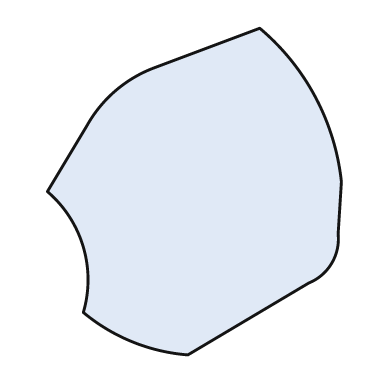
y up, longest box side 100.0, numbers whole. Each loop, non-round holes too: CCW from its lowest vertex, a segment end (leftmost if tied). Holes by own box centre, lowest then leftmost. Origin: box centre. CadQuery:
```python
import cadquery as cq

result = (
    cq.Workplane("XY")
    .moveTo(-2.0, -50.0)
    .lineTo(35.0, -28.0)
    .threePointArc((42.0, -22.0), (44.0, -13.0))
    .lineTo(45.0, 3.0)
    .threePointArc((37.0, 29.0), (20.0, 50.0))
    .lineTo(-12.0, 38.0)
    .threePointArc((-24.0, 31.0), (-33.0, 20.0))
    .lineTo(-45.0, 0.0)
    .threePointArc((-34.0, -17.0), (-34.0, -37.0))
    .threePointArc((-19.0, -46.0), (-2.0, -50.0))
    .close()
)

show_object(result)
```